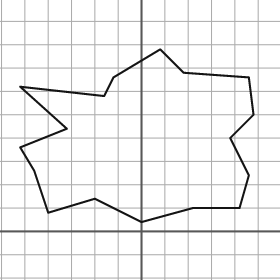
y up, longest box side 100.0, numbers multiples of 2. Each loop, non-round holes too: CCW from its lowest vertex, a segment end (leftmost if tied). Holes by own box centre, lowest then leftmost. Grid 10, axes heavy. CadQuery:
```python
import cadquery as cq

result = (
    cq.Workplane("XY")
    .moveTo(0.0, 4.0)
    .lineTo(22.0, 10.0)
    .lineTo(42.0, 10.0)
    .lineTo(46.0, 24.0)
    .lineTo(38.0, 40.0)
    .lineTo(48.0, 50.0)
    .lineTo(46.0, 66.0)
    .lineTo(18.0, 68.0)
    .lineTo(8.0, 78.0)
    .lineTo(-12.0, 66.0)
    .lineTo(-16.0, 58.0)
    .lineTo(-52.0, 62.0)
    .lineTo(-32.0, 44.0)
    .lineTo(-52.0, 36.0)
    .lineTo(-46.0, 26.0)
    .lineTo(-40.0, 8.0)
    .lineTo(-20.0, 14.0)
    .close()
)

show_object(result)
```